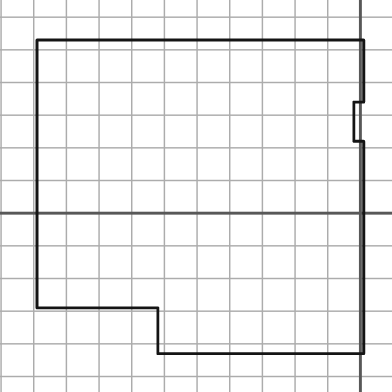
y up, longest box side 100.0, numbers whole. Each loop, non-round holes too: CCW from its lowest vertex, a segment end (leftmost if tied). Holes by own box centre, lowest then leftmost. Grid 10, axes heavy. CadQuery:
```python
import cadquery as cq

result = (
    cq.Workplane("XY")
    .moveTo(-62.0, -43.0)
    .lineTo(1.0, -43.0)
    .lineTo(1.0, 22.0)
    .lineTo(-2.0, 22.0)
    .lineTo(-2.0, 34.0)
    .lineTo(1.0, 34.0)
    .lineTo(1.0, 53.0)
    .lineTo(-99.0, 53.0)
    .lineTo(-99.0, -29.0)
    .lineTo(-62.0, -29.0)
    .close()
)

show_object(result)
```